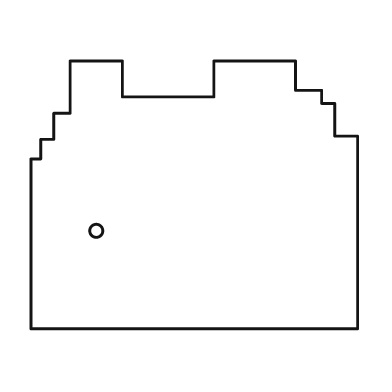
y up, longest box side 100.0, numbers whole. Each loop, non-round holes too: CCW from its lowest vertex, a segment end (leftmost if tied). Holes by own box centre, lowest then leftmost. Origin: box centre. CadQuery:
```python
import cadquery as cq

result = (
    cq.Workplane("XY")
    .moveTo(-50.0, -41.0)
    .lineTo(50.0, -41.0)
    .lineTo(50.0, 18.0)
    .lineTo(43.0, 18.0)
    .lineTo(43.0, 28.0)
    .lineTo(39.0, 28.0)
    .lineTo(39.0, 32.0)
    .lineTo(31.0, 32.0)
    .lineTo(31.0, 41.0)
    .lineTo(6.0, 41.0)
    .lineTo(6.0, 30.0)
    .lineTo(-22.0, 30.0)
    .lineTo(-22.0, 41.0)
    .lineTo(-38.0, 41.0)
    .lineTo(-38.0, 25.0)
    .lineTo(-43.0, 25.0)
    .lineTo(-43.0, 17.0)
    .lineTo(-47.0, 17.0)
    .lineTo(-47.0, 11.0)
    .lineTo(-50.0, 11.0)
    .close()
    .moveTo(-30.0, -11.0)
    .circle(2.0)
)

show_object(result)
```